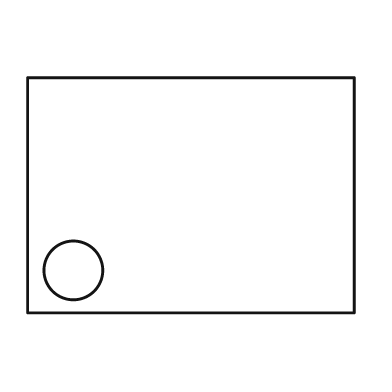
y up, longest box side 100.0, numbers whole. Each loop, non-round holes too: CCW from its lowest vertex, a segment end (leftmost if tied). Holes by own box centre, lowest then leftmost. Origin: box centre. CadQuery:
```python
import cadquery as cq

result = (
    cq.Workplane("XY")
    .moveTo(-50.0, -36.0)
    .lineTo(50.0, -36.0)
    .lineTo(50.0, 36.0)
    .lineTo(-50.0, 36.0)
    .close()
    .moveTo(-36.0, -23.0)
    .circle(9.0)
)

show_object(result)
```